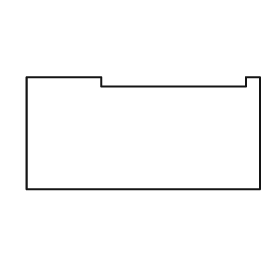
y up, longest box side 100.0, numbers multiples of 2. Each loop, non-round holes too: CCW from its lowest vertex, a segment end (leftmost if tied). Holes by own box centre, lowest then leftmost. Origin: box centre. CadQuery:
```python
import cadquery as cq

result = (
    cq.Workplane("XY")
    .moveTo(-50.0, -24.0)
    .lineTo(50.0, -24.0)
    .lineTo(50.0, 24.0)
    .lineTo(44.0, 24.0)
    .lineTo(44.0, 20.0)
    .lineTo(-18.0, 20.0)
    .lineTo(-18.0, 24.0)
    .lineTo(-50.0, 24.0)
    .close()
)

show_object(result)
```